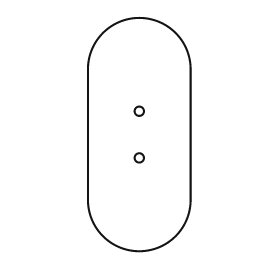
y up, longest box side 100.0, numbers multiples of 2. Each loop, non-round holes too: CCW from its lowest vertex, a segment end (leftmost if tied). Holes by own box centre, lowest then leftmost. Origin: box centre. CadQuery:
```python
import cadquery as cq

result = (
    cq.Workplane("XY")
    .moveTo(-22.0, -28.0)
    .threePointArc((0.0, -50.0), (22.0, -28.0))
    .lineTo(22.0, 28.0)
    .threePointArc((0.0, 50.0), (-22.0, 28.0))
    .close()
    .moveTo(0.0, -10.0)
    .circle(2.0)
    .moveTo(0.0, 10.0)
    .circle(2.0)
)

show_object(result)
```